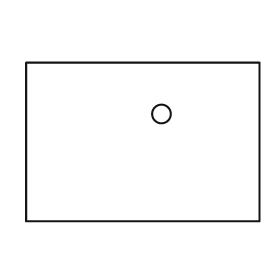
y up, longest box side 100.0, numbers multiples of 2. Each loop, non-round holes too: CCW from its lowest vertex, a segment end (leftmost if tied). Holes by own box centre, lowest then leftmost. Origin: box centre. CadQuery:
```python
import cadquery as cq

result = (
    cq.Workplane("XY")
    .moveTo(-50.0, -34.0)
    .lineTo(50.0, -34.0)
    .lineTo(50.0, 34.0)
    .lineTo(-50.0, 34.0)
    .close()
    .moveTo(8.0, 12.0)
    .circle(4.0)
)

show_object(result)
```